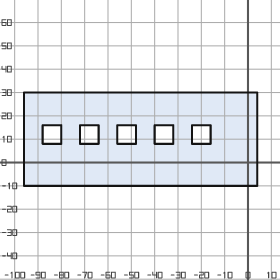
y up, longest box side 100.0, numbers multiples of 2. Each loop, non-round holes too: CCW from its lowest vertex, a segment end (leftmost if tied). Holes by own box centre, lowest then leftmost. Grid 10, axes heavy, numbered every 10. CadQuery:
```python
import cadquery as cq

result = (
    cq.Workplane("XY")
    .moveTo(-96.0, -10.0)
    .lineTo(4.0, -10.0)
    .lineTo(4.0, 30.0)
    .lineTo(-96.0, 30.0)
    .close()
    .moveTo(-88.0, 8.0)
    .lineTo(-80.0, 8.0)
    .lineTo(-80.0, 16.0)
    .lineTo(-88.0, 16.0)
    .close()
    .moveTo(-72.0, 8.0)
    .lineTo(-64.0, 8.0)
    .lineTo(-64.0, 16.0)
    .lineTo(-72.0, 16.0)
    .close()
    .moveTo(-56.0, 8.0)
    .lineTo(-48.0, 8.0)
    .lineTo(-48.0, 16.0)
    .lineTo(-56.0, 16.0)
    .close()
    .moveTo(-40.0, 8.0)
    .lineTo(-32.0, 8.0)
    .lineTo(-32.0, 16.0)
    .lineTo(-40.0, 16.0)
    .close()
    .moveTo(-24.0, 8.0)
    .lineTo(-16.0, 8.0)
    .lineTo(-16.0, 16.0)
    .lineTo(-24.0, 16.0)
    .close()
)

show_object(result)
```